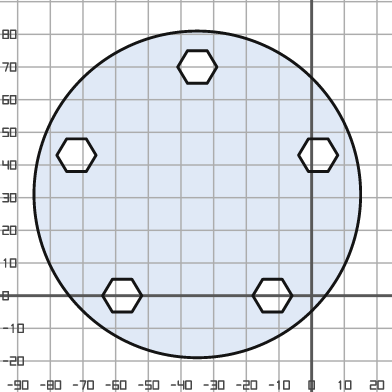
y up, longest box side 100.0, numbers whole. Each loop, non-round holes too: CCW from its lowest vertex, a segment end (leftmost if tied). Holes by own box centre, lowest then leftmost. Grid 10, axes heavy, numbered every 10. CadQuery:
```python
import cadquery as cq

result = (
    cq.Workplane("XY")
    .moveTo(-35.0, 31.0)
    .circle(50.0)
    .moveTo(-61.0, -5.0)
    .lineTo(-55.0, -5.0)
    .lineTo(-52.0, 0.0)
    .lineTo(-55.0, 5.0)
    .lineTo(-61.0, 5.0)
    .lineTo(-64.0, 0.0)
    .close()
    .moveTo(-15.0, -5.0)
    .lineTo(-9.0, -5.0)
    .lineTo(-6.0, 0.0)
    .lineTo(-9.0, 5.0)
    .lineTo(-15.0, 5.0)
    .lineTo(-18.0, 0.0)
    .close()
    .moveTo(-75.0, 38.0)
    .lineTo(-69.0, 38.0)
    .lineTo(-66.0, 43.0)
    .lineTo(-69.0, 48.0)
    .lineTo(-75.0, 48.0)
    .lineTo(-78.0, 43.0)
    .close()
    .moveTo(-1.0, 38.0)
    .lineTo(5.0, 38.0)
    .lineTo(8.0, 43.0)
    .lineTo(5.0, 48.0)
    .lineTo(-1.0, 48.0)
    .lineTo(-4.0, 43.0)
    .close()
    .moveTo(-38.0, 65.0)
    .lineTo(-32.0, 65.0)
    .lineTo(-29.0, 70.0)
    .lineTo(-32.0, 75.0)
    .lineTo(-38.0, 75.0)
    .lineTo(-41.0, 70.0)
    .close()
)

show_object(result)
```